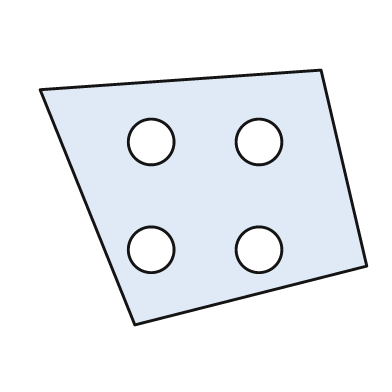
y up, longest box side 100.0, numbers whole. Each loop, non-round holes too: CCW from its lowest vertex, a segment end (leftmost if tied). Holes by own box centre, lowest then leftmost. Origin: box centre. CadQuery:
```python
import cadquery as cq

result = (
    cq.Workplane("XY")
    .moveTo(-21.0, -39.0)
    .lineTo(50.0, -21.0)
    .lineTo(36.0, 39.0)
    .lineTo(-50.0, 33.0)
    .close()
    .moveTo(-16.0, -16.0)
    .circle(7.0)
    .moveTo(17.0, -16.0)
    .circle(7.0)
    .moveTo(-16.0, 17.0)
    .circle(7.0)
    .moveTo(17.0, 17.0)
    .circle(7.0)
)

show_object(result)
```